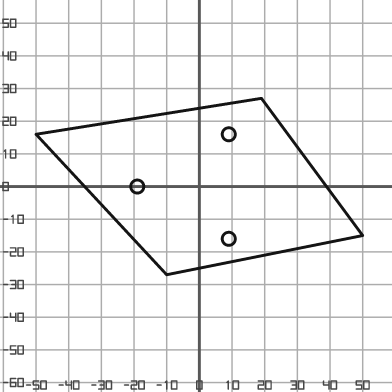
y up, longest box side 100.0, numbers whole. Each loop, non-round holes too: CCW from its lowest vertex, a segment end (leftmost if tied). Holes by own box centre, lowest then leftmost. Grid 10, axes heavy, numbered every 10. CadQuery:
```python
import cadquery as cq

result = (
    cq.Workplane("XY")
    .moveTo(-10.0, -27.0)
    .lineTo(50.0, -15.0)
    .lineTo(19.0, 27.0)
    .lineTo(-50.0, 16.0)
    .close()
    .moveTo(9.0, -16.0)
    .circle(2.0)
    .moveTo(-19.0, 0.0)
    .circle(2.0)
    .moveTo(9.0, 16.0)
    .circle(2.0)
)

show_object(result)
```